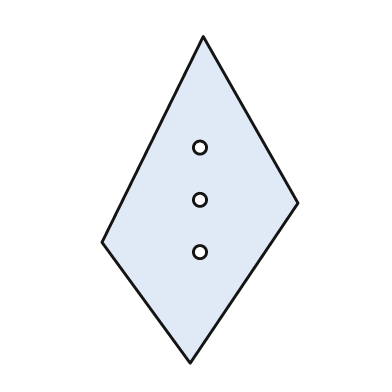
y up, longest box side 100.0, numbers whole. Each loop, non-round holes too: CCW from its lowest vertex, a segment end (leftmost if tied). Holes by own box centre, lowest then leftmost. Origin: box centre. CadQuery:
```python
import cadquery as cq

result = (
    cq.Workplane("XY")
    .moveTo(-3.0, -50.0)
    .lineTo(30.0, -1.0)
    .lineTo(1.0, 50.0)
    .lineTo(-30.0, -13.0)
    .close()
    .moveTo(0.0, -16.0)
    .circle(2.0)
    .moveTo(0.0, 0.0)
    .circle(2.0)
    .moveTo(0.0, 16.0)
    .circle(2.0)
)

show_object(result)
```